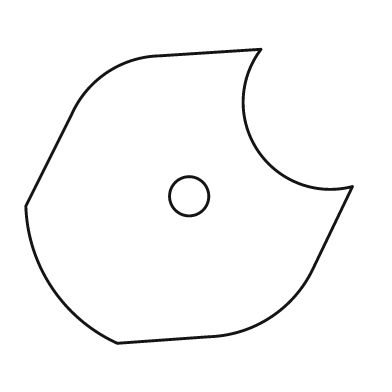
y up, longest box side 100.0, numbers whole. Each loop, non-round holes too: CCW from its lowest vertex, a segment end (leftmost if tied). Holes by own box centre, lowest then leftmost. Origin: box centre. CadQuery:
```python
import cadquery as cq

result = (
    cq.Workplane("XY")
    .moveTo(-22.0, -45.0)
    .lineTo(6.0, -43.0)
    .threePointArc((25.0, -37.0), (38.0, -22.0))
    .lineTo(50.0, 3.0)
    .threePointArc((21.0, 14.0), (22.0, 45.0))
    .lineTo(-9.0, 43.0)
    .threePointArc((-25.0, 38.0), (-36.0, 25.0))
    .lineTo(-50.0, -3.0)
    .threePointArc((-42.0, -28.0), (-22.0, -45.0))
    .close()
    .moveTo(0.0, 0.0)
    .circle(6.0)
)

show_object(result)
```